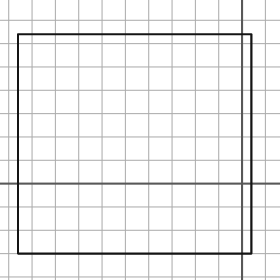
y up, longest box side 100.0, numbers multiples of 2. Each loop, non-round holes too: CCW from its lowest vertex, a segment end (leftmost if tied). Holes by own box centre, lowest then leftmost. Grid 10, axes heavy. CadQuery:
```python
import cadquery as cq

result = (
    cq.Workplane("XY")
    .moveTo(-96.0, -30.0)
    .lineTo(4.0, -30.0)
    .lineTo(4.0, 64.0)
    .lineTo(-96.0, 64.0)
    .close()
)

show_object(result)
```